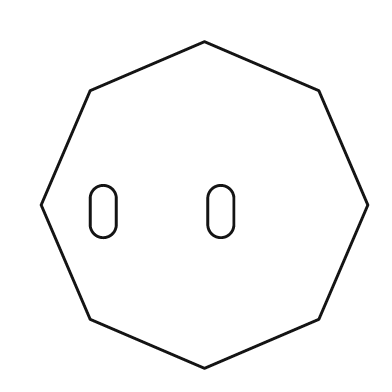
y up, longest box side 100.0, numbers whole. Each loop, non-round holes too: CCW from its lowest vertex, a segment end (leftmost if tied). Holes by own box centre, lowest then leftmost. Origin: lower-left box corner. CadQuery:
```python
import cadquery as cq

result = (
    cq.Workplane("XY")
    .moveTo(50.0, 0.0)
    .lineTo(85.0, 15.0)
    .lineTo(100.0, 50.0)
    .lineTo(85.0, 85.0)
    .lineTo(50.0, 100.0)
    .lineTo(15.0, 85.0)
    .lineTo(0.0, 50.0)
    .lineTo(15.0, 15.0)
    .close()
    .moveTo(15.0, 44.0)
    .threePointArc((19.0, 40.0), (23.0, 44.0))
    .lineTo(23.0, 52.0)
    .threePointArc((19.0, 56.0), (15.0, 52.0))
    .close()
    .moveTo(51.0, 44.0)
    .threePointArc((55.0, 40.0), (59.0, 44.0))
    .lineTo(59.0, 52.0)
    .threePointArc((55.0, 56.0), (51.0, 52.0))
    .close()
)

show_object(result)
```